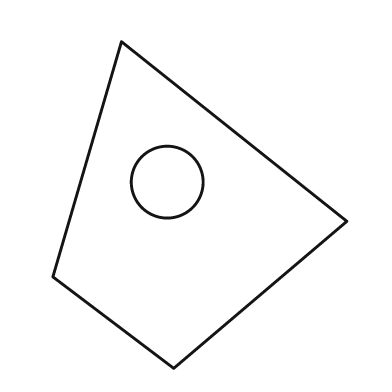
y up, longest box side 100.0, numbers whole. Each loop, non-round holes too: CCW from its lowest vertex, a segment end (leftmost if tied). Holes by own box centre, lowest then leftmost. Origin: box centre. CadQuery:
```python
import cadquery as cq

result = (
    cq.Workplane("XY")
    .moveTo(-8.0, -50.0)
    .lineTo(45.0, -5.0)
    .lineTo(-24.0, 50.0)
    .lineTo(-45.0, -22.0)
    .close()
    .moveTo(-10.0, 7.0)
    .circle(11.0)
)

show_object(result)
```